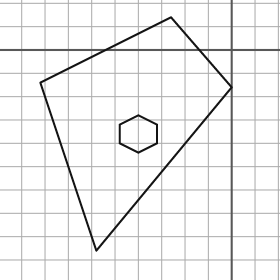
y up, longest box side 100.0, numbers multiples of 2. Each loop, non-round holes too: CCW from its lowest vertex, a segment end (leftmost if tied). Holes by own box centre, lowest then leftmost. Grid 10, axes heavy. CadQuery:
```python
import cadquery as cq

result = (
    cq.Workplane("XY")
    .moveTo(-58.0, -86.0)
    .lineTo(0.0, -16.0)
    .lineTo(-26.0, 14.0)
    .lineTo(-82.0, -14.0)
    .close()
    .moveTo(-40.0, -44.0)
    .lineTo(-32.0, -40.0)
    .lineTo(-32.0, -32.0)
    .lineTo(-40.0, -28.0)
    .lineTo(-48.0, -32.0)
    .lineTo(-48.0, -40.0)
    .close()
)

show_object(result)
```